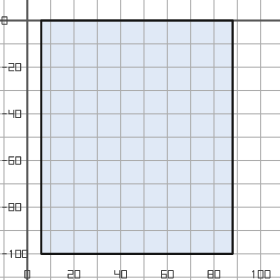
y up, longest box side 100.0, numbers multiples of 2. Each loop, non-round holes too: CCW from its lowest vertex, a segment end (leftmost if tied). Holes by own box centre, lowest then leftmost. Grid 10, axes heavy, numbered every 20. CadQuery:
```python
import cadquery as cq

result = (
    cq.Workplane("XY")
    .moveTo(6.0, -100.0)
    .lineTo(88.0, -100.0)
    .lineTo(88.0, 0.0)
    .lineTo(6.0, 0.0)
    .close()
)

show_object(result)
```